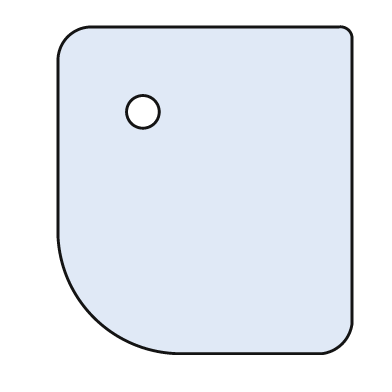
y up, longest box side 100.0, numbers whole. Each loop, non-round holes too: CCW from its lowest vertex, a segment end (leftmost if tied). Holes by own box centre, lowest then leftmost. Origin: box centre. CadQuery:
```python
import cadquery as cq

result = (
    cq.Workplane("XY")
    .moveTo(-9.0, -50.0)
    .lineTo(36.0, -50.0)
    .threePointArc((42.0, -47.0), (45.0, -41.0))
    .lineTo(45.0, 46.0)
    .threePointArc((44.0, 49.0), (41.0, 50.0))
    .lineTo(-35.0, 50.0)
    .threePointArc((-42.0, 47.0), (-45.0, 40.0))
    .lineTo(-45.0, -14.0)
    .threePointArc((-34.0, -39.0), (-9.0, -50.0))
    .close()
    .moveTo(-19.0, 24.0)
    .circle(5.0)
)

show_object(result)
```